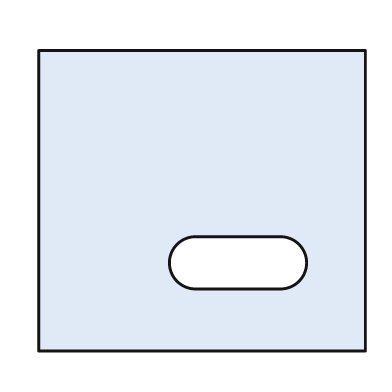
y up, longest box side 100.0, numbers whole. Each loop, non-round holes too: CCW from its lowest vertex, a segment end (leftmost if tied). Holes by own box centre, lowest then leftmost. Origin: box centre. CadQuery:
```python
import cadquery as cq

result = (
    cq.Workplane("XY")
    .moveTo(-50.0, -46.0)
    .lineTo(50.0, -46.0)
    .lineTo(50.0, 46.0)
    .lineTo(-50.0, 46.0)
    .close()
    .moveTo(-2.0, -27.0)
    .lineTo(24.0, -27.0)
    .threePointArc((32.0, -19.0), (24.0, -11.0))
    .lineTo(-2.0, -11.0)
    .threePointArc((-10.0, -19.0), (-2.0, -27.0))
    .close()
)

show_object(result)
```